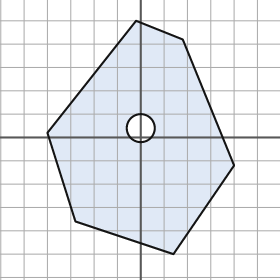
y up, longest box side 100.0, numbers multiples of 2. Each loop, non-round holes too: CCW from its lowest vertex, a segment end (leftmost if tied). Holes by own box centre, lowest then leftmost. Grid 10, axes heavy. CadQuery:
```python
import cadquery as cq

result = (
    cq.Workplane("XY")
    .moveTo(14.0, -50.0)
    .lineTo(40.0, -12.0)
    .lineTo(18.0, 42.0)
    .lineTo(-2.0, 50.0)
    .lineTo(-40.0, 2.0)
    .lineTo(-28.0, -36.0)
    .close()
    .moveTo(0.0, 4.0)
    .circle(6.0)
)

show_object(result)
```